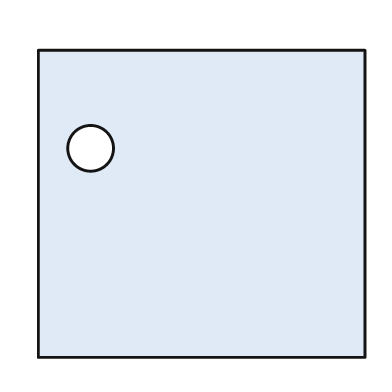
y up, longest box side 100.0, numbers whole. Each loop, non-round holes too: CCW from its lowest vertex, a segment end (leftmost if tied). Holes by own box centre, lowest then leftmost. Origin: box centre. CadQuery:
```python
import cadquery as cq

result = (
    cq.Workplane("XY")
    .moveTo(-50.0, -47.0)
    .lineTo(50.0, -47.0)
    .lineTo(50.0, 47.0)
    .lineTo(-50.0, 47.0)
    .close()
    .moveTo(-34.0, 17.0)
    .circle(7.0)
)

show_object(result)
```